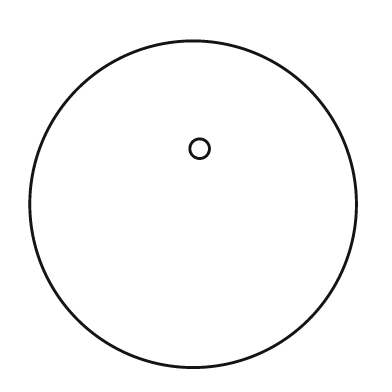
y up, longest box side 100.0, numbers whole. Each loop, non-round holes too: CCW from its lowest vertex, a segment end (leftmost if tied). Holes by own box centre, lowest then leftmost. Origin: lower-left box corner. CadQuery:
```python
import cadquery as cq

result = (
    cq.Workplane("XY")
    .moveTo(50.0, 50.0)
    .circle(50.0)
    .moveTo(52.0, 67.0)
    .circle(3.0)
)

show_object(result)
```